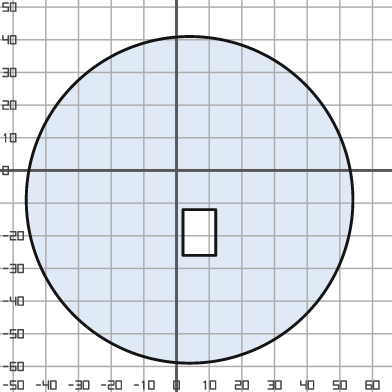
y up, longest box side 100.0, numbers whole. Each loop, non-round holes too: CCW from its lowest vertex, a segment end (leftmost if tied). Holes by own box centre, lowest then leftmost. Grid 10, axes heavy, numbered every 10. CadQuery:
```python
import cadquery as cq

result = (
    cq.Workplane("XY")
    .moveTo(4.0, -9.0)
    .circle(50.0)
    .moveTo(2.0, -26.0)
    .lineTo(12.0, -26.0)
    .lineTo(12.0, -12.0)
    .lineTo(2.0, -12.0)
    .close()
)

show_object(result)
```